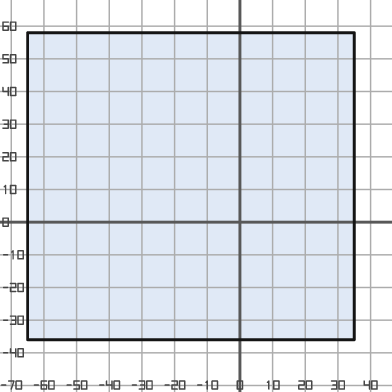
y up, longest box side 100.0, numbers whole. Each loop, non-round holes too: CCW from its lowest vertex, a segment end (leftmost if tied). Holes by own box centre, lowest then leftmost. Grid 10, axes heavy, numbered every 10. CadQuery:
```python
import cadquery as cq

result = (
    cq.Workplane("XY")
    .moveTo(-65.0, -36.0)
    .lineTo(35.0, -36.0)
    .lineTo(35.0, 58.0)
    .lineTo(-65.0, 58.0)
    .close()
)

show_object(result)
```